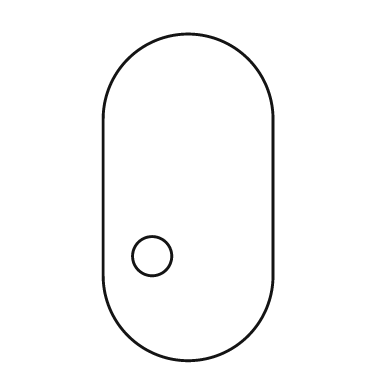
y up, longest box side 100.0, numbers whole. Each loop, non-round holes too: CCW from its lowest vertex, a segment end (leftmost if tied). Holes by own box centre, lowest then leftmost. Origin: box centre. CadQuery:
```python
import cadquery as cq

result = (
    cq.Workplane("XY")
    .moveTo(-26.0, -24.0)
    .threePointArc((0.0, -50.0), (26.0, -24.0))
    .lineTo(26.0, 24.0)
    .threePointArc((0.0, 50.0), (-26.0, 24.0))
    .close()
    .moveTo(-11.0, -18.0)
    .circle(6.0)
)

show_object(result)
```